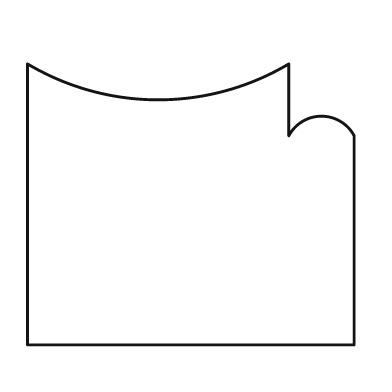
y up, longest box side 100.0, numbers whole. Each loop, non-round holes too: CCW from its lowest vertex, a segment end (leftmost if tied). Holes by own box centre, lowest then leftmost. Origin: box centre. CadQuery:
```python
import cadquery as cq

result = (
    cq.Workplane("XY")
    .moveTo(-50.0, -43.0)
    .lineTo(50.0, -43.0)
    .lineTo(50.0, 21.0)
    .threePointArc((40.0, 27.0), (30.0, 21.0))
    .lineTo(30.0, 43.0)
    .threePointArc((-10.0, 32.0), (-50.0, 43.0))
    .close()
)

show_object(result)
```